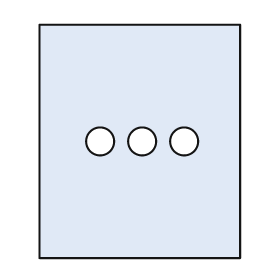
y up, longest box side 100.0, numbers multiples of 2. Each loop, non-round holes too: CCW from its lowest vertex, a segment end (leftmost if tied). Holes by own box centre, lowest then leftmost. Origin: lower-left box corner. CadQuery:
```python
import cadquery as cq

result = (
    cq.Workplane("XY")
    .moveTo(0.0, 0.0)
    .lineTo(86.0, 0.0)
    .lineTo(86.0, 100.0)
    .lineTo(0.0, 100.0)
    .close()
    .moveTo(26.0, 50.0)
    .circle(6.0)
    .moveTo(44.0, 50.0)
    .circle(6.0)
    .moveTo(62.0, 50.0)
    .circle(6.0)
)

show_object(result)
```